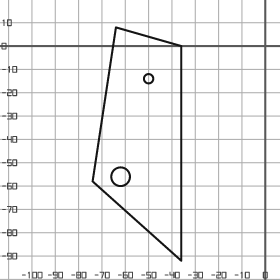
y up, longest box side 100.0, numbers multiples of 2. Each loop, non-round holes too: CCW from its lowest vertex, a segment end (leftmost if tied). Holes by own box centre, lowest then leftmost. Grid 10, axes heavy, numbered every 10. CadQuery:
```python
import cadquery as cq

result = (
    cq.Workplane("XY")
    .moveTo(-36.0, -92.0)
    .lineTo(-36.0, 0.0)
    .lineTo(-64.0, 8.0)
    .lineTo(-74.0, -58.0)
    .close()
    .moveTo(-62.0, -56.0)
    .circle(4.0)
    .moveTo(-50.0, -14.0)
    .circle(2.0)
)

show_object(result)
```